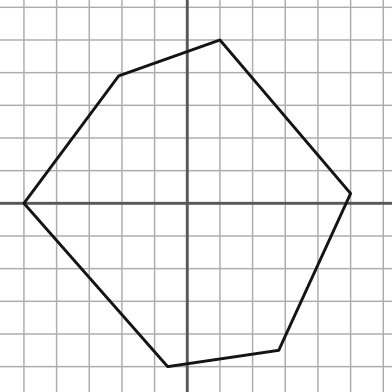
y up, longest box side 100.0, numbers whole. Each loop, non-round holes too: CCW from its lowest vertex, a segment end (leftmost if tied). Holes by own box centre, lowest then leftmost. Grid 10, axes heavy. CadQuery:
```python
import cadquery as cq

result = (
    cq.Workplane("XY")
    .moveTo(-6.0, -50.0)
    .lineTo(28.0, -45.0)
    .lineTo(50.0, 3.0)
    .lineTo(10.0, 50.0)
    .lineTo(-21.0, 39.0)
    .lineTo(-50.0, 0.0)
    .close()
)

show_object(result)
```